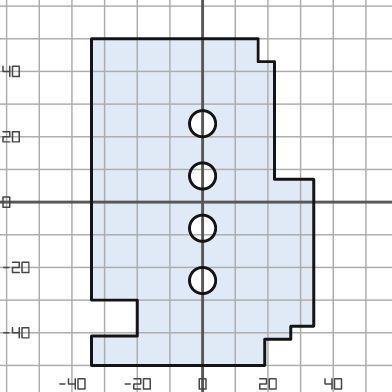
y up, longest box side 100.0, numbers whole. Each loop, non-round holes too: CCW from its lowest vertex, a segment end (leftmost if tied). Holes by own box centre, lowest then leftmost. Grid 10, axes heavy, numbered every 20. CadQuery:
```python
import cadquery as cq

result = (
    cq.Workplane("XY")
    .moveTo(-34.0, -50.0)
    .lineTo(19.0, -50.0)
    .lineTo(19.0, -42.0)
    .lineTo(27.0, -42.0)
    .lineTo(27.0, -38.0)
    .lineTo(34.0, -38.0)
    .lineTo(34.0, 7.0)
    .lineTo(22.0, 7.0)
    .lineTo(22.0, 43.0)
    .lineTo(17.0, 43.0)
    .lineTo(17.0, 50.0)
    .lineTo(-34.0, 50.0)
    .lineTo(-34.0, -30.0)
    .lineTo(-20.0, -30.0)
    .lineTo(-20.0, -41.0)
    .lineTo(-34.0, -41.0)
    .close()
    .moveTo(0.0, -24.0)
    .circle(4.0)
    .moveTo(0.0, -8.0)
    .circle(4.0)
    .moveTo(0.0, 8.0)
    .circle(4.0)
    .moveTo(0.0, 24.0)
    .circle(4.0)
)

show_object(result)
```